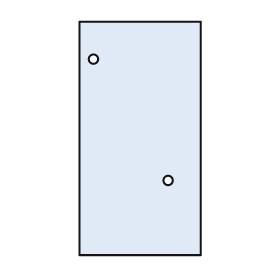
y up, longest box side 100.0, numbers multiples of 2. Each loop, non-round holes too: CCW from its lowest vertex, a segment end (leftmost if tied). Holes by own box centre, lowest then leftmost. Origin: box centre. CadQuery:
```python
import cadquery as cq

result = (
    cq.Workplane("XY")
    .moveTo(-26.0, -50.0)
    .lineTo(26.0, -50.0)
    .lineTo(26.0, 50.0)
    .lineTo(-26.0, 50.0)
    .close()
    .moveTo(12.0, -18.0)
    .circle(2.0)
    .moveTo(-20.0, 34.0)
    .circle(2.0)
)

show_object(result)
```